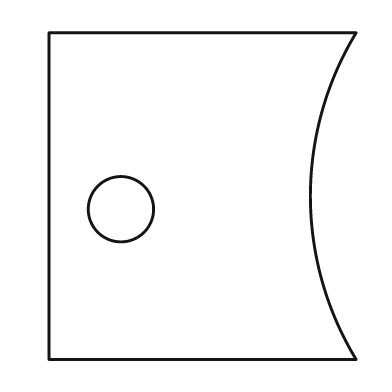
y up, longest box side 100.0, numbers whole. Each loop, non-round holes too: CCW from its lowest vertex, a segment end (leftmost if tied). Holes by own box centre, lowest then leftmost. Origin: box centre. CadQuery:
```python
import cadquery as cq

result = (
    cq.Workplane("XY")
    .moveTo(-47.0, -50.0)
    .lineTo(47.0, -50.0)
    .threePointArc((33.0, 0.0), (47.0, 50.0))
    .lineTo(-47.0, 50.0)
    .close()
    .moveTo(-25.0, -4.0)
    .circle(10.0)
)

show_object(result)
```